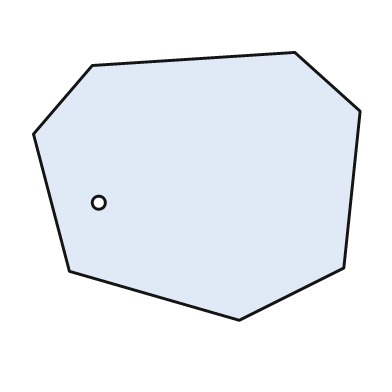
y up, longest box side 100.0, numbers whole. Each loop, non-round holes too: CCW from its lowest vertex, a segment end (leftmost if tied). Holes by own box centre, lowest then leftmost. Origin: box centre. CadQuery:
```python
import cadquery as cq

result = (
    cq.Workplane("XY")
    .moveTo(13.0, -41.0)
    .lineTo(45.0, -25.0)
    .lineTo(50.0, 23.0)
    .lineTo(30.0, 41.0)
    .lineTo(-32.0, 37.0)
    .lineTo(-50.0, 16.0)
    .lineTo(-39.0, -26.0)
    .close()
    .moveTo(-30.0, -5.0)
    .circle(2.0)
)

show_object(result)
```